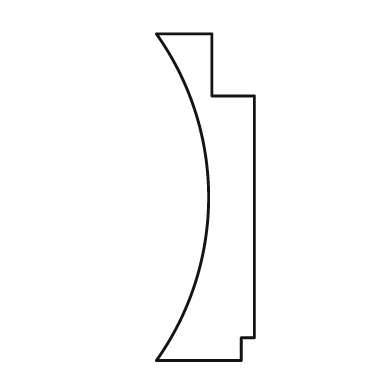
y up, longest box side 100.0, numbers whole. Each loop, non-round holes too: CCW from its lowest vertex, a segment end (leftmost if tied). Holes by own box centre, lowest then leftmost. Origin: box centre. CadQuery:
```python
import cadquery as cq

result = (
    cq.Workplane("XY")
    .moveTo(-15.0, -50.0)
    .lineTo(11.0, -50.0)
    .lineTo(11.0, -43.0)
    .lineTo(15.0, -43.0)
    .lineTo(15.0, 31.0)
    .lineTo(2.0, 31.0)
    .lineTo(2.0, 50.0)
    .lineTo(-15.0, 50.0)
    .threePointArc((1.0, 0.0), (-15.0, -50.0))
    .close()
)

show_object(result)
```